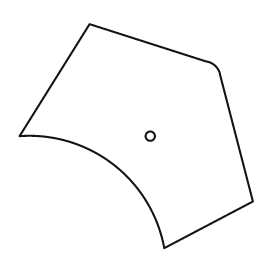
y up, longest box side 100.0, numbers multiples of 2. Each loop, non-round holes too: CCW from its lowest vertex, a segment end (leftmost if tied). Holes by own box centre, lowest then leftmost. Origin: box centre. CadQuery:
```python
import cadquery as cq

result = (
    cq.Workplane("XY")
    .moveTo(12.0, -48.0)
    .lineTo(50.0, -28.0)
    .lineTo(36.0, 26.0)
    .threePointArc((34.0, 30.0), (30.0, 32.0))
    .lineTo(-20.0, 48.0)
    .lineTo(-50.0, 0.0)
    .threePointArc((-10.0, -12.0), (12.0, -48.0))
    .close()
    .moveTo(6.0, 0.0)
    .circle(2.0)
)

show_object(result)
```